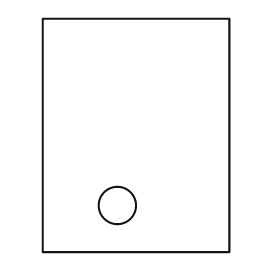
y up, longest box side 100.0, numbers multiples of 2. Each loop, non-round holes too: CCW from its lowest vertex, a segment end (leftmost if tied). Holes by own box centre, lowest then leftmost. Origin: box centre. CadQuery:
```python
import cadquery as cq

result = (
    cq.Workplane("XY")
    .moveTo(-40.0, -50.0)
    .lineTo(40.0, -50.0)
    .lineTo(40.0, 50.0)
    .lineTo(-40.0, 50.0)
    .close()
    .moveTo(-8.0, -30.0)
    .circle(8.0)
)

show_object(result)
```